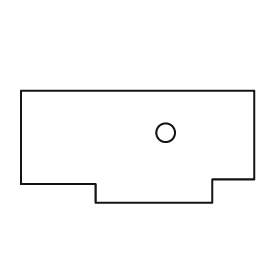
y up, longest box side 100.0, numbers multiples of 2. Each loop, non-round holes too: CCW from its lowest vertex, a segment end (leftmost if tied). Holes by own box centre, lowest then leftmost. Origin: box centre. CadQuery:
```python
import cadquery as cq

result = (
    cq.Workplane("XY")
    .moveTo(-18.0, -24.0)
    .lineTo(32.0, -24.0)
    .lineTo(32.0, -14.0)
    .lineTo(50.0, -14.0)
    .lineTo(50.0, 24.0)
    .lineTo(-50.0, 24.0)
    .lineTo(-50.0, -16.0)
    .lineTo(-18.0, -16.0)
    .close()
    .moveTo(12.0, 6.0)
    .circle(4.0)
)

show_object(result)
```